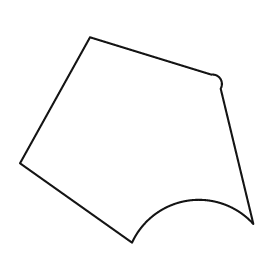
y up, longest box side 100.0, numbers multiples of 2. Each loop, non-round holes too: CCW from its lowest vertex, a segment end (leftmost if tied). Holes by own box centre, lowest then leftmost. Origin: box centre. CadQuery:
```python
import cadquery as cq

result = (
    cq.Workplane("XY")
    .moveTo(-2.0, -44.0)
    .threePointArc((22.0, -26.0), (50.0, -36.0))
    .lineTo(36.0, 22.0)
    .threePointArc((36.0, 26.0), (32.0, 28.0))
    .lineTo(-20.0, 44.0)
    .lineTo(-50.0, -10.0)
    .close()
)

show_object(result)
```